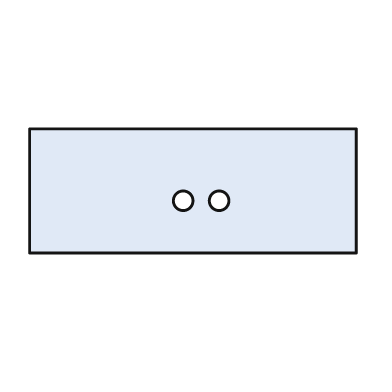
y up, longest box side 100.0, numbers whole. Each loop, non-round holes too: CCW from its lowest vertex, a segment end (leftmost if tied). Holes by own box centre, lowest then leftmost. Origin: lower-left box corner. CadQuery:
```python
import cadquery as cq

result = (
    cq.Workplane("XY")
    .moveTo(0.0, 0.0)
    .lineTo(100.0, 0.0)
    .lineTo(100.0, 38.0)
    .lineTo(0.0, 38.0)
    .close()
    .moveTo(47.0, 16.0)
    .circle(3.0)
    .moveTo(58.0, 16.0)
    .circle(3.0)
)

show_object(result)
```